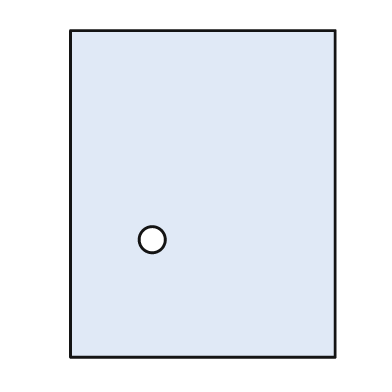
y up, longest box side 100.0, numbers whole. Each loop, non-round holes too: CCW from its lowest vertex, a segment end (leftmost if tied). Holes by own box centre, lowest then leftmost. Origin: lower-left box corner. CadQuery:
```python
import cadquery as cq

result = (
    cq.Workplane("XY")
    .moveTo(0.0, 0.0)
    .lineTo(81.0, 0.0)
    .lineTo(81.0, 100.0)
    .lineTo(0.0, 100.0)
    .close()
    .moveTo(25.0, 36.0)
    .circle(4.0)
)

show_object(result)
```